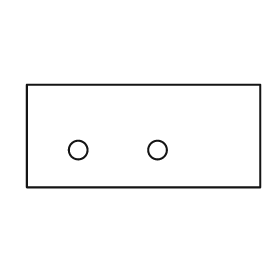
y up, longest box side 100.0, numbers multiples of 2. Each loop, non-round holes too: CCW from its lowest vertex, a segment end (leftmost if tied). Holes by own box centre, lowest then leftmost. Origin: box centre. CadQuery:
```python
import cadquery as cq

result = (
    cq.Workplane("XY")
    .moveTo(-50.0, -22.0)
    .lineTo(50.0, -22.0)
    .lineTo(50.0, 22.0)
    .lineTo(-50.0, 22.0)
    .close()
    .moveTo(-28.0, -6.0)
    .circle(4.0)
    .moveTo(6.0, -6.0)
    .circle(4.0)
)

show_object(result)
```